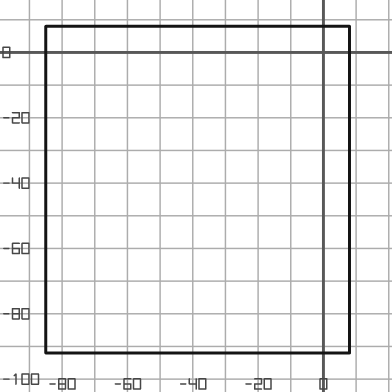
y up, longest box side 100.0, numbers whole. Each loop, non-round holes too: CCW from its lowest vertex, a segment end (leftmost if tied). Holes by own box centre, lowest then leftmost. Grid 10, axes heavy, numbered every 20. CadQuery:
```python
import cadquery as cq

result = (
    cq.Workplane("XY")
    .moveTo(-85.0, -92.0)
    .lineTo(8.0, -92.0)
    .lineTo(8.0, 8.0)
    .lineTo(-85.0, 8.0)
    .close()
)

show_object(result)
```